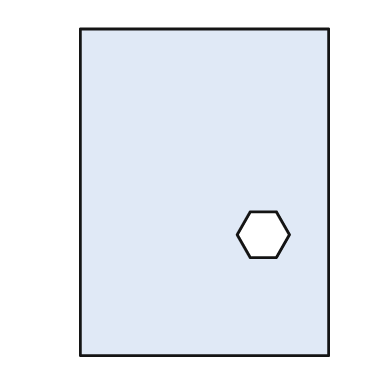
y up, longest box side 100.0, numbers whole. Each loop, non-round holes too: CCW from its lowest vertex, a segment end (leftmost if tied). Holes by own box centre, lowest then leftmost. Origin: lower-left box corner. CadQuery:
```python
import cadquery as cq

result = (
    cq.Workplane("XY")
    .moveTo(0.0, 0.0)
    .lineTo(76.0, 0.0)
    .lineTo(76.0, 100.0)
    .lineTo(0.0, 100.0)
    .close()
    .moveTo(52.0, 30.0)
    .lineTo(60.0, 30.0)
    .lineTo(64.0, 37.0)
    .lineTo(60.0, 44.0)
    .lineTo(52.0, 44.0)
    .lineTo(48.0, 37.0)
    .close()
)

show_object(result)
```